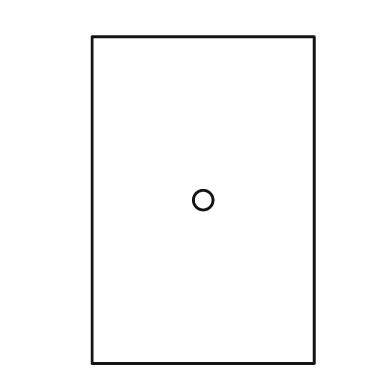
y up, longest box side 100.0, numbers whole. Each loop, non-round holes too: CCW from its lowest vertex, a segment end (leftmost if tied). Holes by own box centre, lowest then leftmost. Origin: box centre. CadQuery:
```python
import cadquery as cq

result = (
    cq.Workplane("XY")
    .moveTo(-34.0, -50.0)
    .lineTo(34.0, -50.0)
    .lineTo(34.0, 50.0)
    .lineTo(-34.0, 50.0)
    .close()
    .moveTo(0.0, 0.0)
    .circle(3.0)
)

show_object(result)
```